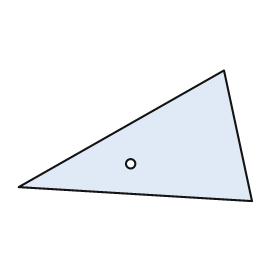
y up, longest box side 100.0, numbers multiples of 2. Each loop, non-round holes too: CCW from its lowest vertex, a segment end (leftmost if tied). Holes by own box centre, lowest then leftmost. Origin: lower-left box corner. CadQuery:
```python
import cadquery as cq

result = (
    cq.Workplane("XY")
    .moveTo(100.0, 0.0)
    .lineTo(88.0, 56.0)
    .lineTo(0.0, 6.0)
    .close()
    .moveTo(48.0, 16.0)
    .circle(2.0)
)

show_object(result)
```